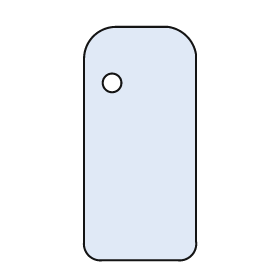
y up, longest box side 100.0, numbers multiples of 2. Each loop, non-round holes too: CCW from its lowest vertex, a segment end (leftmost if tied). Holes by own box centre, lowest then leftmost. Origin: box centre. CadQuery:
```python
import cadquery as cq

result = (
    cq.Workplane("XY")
    .moveTo(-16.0, -50.0)
    .lineTo(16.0, -50.0)
    .threePointArc((22.0, -48.0), (24.0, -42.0))
    .lineTo(24.0, 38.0)
    .threePointArc((20.0, 46.0), (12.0, 50.0))
    .lineTo(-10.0, 50.0)
    .threePointArc((-20.0, 46.0), (-24.0, 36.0))
    .lineTo(-24.0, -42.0)
    .threePointArc((-22.0, -48.0), (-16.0, -50.0))
    .close()
    .moveTo(-12.0, 26.0)
    .circle(4.0)
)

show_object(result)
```